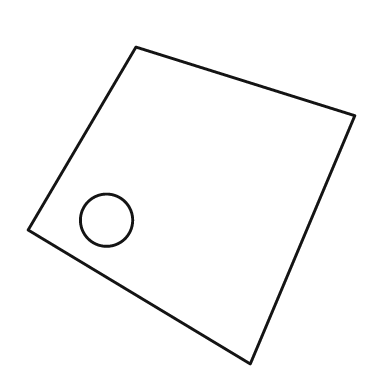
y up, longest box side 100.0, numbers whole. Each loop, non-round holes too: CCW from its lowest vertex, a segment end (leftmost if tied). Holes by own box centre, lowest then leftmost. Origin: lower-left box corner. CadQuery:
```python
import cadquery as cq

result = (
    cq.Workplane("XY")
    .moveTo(68.0, 0.0)
    .lineTo(100.0, 76.0)
    .lineTo(33.0, 97.0)
    .lineTo(0.0, 41.0)
    .close()
    .moveTo(24.0, 44.0)
    .circle(8.0)
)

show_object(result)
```